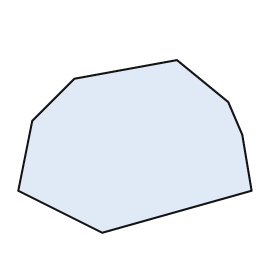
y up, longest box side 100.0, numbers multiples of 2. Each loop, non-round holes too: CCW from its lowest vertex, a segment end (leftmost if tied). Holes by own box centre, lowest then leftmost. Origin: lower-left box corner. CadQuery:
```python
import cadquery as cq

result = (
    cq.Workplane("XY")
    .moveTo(36.0, 0.0)
    .lineTo(100.0, 18.0)
    .lineTo(96.0, 42.0)
    .lineTo(90.0, 56.0)
    .lineTo(68.0, 74.0)
    .lineTo(24.0, 66.0)
    .lineTo(6.0, 48.0)
    .lineTo(0.0, 18.0)
    .close()
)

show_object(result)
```